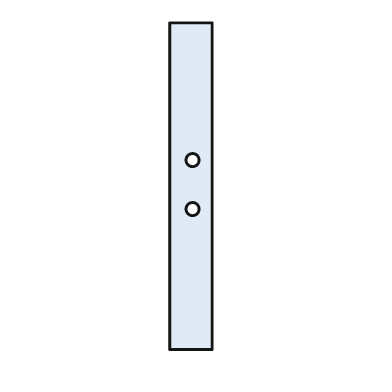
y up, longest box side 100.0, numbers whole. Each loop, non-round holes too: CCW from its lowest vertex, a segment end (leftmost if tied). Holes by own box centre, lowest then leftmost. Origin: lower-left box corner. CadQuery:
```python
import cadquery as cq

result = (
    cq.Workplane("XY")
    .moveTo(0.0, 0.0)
    .lineTo(13.0, 0.0)
    .lineTo(13.0, 100.0)
    .lineTo(0.0, 100.0)
    .close()
    .moveTo(7.0, 43.0)
    .circle(2.0)
    .moveTo(7.0, 58.0)
    .circle(2.0)
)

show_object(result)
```